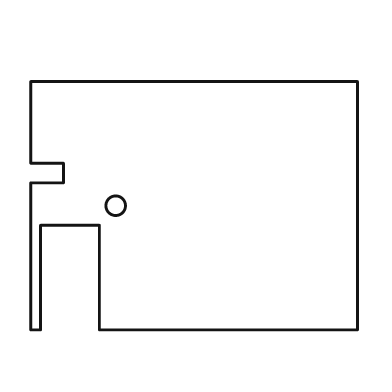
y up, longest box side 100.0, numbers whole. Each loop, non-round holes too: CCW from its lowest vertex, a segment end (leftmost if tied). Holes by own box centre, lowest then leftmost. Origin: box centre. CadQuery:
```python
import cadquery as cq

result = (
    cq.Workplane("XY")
    .moveTo(-50.0, -38.0)
    .lineTo(-47.0, -38.0)
    .lineTo(-47.0, -6.0)
    .lineTo(-29.0, -6.0)
    .lineTo(-29.0, -38.0)
    .lineTo(50.0, -38.0)
    .lineTo(50.0, 38.0)
    .lineTo(-50.0, 38.0)
    .lineTo(-50.0, 13.0)
    .lineTo(-40.0, 13.0)
    .lineTo(-40.0, 7.0)
    .lineTo(-50.0, 7.0)
    .close()
    .moveTo(-24.0, 0.0)
    .circle(3.0)
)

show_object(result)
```